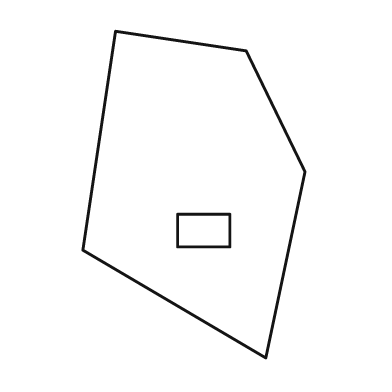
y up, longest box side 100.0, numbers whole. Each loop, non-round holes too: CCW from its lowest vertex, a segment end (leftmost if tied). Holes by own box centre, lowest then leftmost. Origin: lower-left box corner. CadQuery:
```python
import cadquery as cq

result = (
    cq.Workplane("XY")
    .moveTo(56.0, 0.0)
    .lineTo(68.0, 57.0)
    .lineTo(50.0, 94.0)
    .lineTo(10.0, 100.0)
    .lineTo(0.0, 33.0)
    .close()
    .moveTo(29.0, 34.0)
    .lineTo(45.0, 34.0)
    .lineTo(45.0, 44.0)
    .lineTo(29.0, 44.0)
    .close()
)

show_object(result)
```